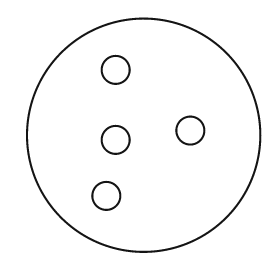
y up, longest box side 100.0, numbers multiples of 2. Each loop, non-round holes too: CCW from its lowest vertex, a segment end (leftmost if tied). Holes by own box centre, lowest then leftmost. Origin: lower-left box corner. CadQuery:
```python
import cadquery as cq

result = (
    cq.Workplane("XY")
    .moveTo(50.0, 50.0)
    .circle(50.0)
    .moveTo(34.0, 24.0)
    .circle(6.0)
    .moveTo(38.0, 48.0)
    .circle(6.0)
    .moveTo(70.0, 52.0)
    .circle(6.0)
    .moveTo(38.0, 78.0)
    .circle(6.0)
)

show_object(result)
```